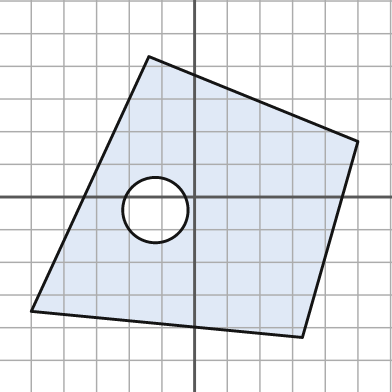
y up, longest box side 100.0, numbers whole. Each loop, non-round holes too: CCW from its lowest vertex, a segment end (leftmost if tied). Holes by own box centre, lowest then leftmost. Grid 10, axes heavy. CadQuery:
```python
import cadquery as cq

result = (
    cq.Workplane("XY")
    .moveTo(33.0, -43.0)
    .lineTo(50.0, 17.0)
    .lineTo(-14.0, 43.0)
    .lineTo(-50.0, -35.0)
    .close()
    .moveTo(-12.0, -4.0)
    .circle(10.0)
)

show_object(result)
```